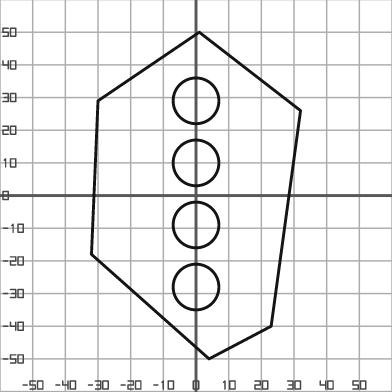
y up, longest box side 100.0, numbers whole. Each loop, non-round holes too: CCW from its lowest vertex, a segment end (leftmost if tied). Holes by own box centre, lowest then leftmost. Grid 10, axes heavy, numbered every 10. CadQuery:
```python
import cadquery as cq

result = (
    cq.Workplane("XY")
    .moveTo(4.0, -50.0)
    .lineTo(23.0, -40.0)
    .lineTo(32.0, 26.0)
    .lineTo(1.0, 50.0)
    .lineTo(-30.0, 29.0)
    .lineTo(-32.0, -18.0)
    .close()
    .moveTo(0.0, -28.0)
    .circle(7.0)
    .moveTo(0.0, -9.0)
    .circle(7.0)
    .moveTo(0.0, 10.0)
    .circle(7.0)
    .moveTo(0.0, 29.0)
    .circle(7.0)
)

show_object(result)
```